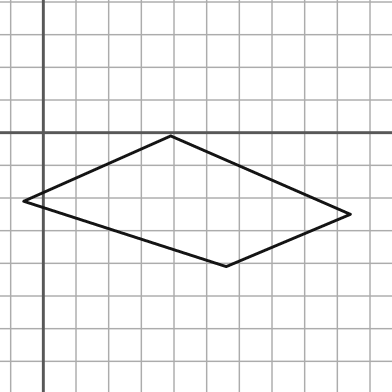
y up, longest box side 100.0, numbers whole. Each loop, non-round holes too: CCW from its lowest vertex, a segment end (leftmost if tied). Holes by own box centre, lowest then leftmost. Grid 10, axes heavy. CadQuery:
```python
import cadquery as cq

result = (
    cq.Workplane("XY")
    .moveTo(56.0, -41.0)
    .lineTo(94.0, -25.0)
    .lineTo(39.0, -1.0)
    .lineTo(-6.0, -21.0)
    .close()
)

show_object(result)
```